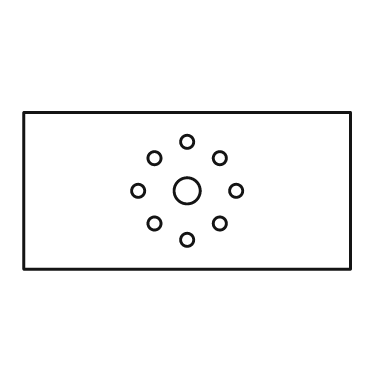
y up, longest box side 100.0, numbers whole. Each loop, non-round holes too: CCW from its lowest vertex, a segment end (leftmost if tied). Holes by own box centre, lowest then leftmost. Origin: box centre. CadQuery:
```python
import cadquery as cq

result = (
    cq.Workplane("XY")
    .moveTo(-50.0, -24.0)
    .lineTo(50.0, -24.0)
    .lineTo(50.0, 24.0)
    .lineTo(-50.0, 24.0)
    .close()
    .moveTo(0.0, -15.0)
    .circle(2.0)
    .moveTo(-10.0, -10.0)
    .circle(2.0)
    .moveTo(10.0, -10.0)
    .circle(2.0)
    .moveTo(-15.0, 0.0)
    .circle(2.0)
    .moveTo(0.0, 0.0)
    .circle(4.0)
    .moveTo(15.0, 0.0)
    .circle(2.0)
    .moveTo(-10.0, 10.0)
    .circle(2.0)
    .moveTo(10.0, 10.0)
    .circle(2.0)
    .moveTo(0.0, 15.0)
    .circle(2.0)
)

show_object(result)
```